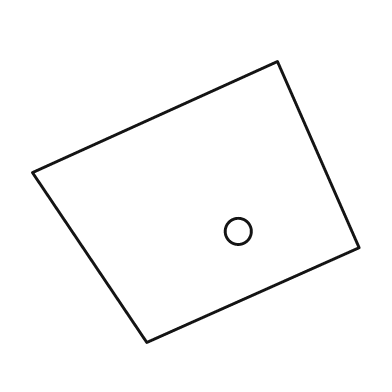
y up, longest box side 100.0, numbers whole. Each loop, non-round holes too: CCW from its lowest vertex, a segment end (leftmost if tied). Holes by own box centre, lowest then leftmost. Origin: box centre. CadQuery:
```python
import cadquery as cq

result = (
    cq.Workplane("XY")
    .moveTo(-15.0, -43.0)
    .lineTo(50.0, -14.0)
    .lineTo(25.0, 43.0)
    .lineTo(-50.0, 9.0)
    .close()
    .moveTo(13.0, -9.0)
    .circle(4.0)
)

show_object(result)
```